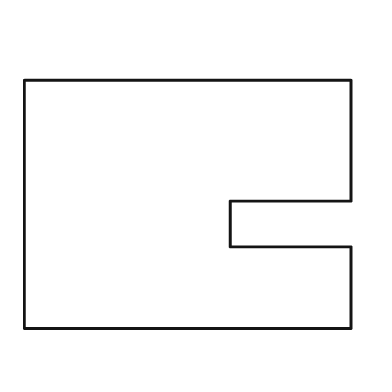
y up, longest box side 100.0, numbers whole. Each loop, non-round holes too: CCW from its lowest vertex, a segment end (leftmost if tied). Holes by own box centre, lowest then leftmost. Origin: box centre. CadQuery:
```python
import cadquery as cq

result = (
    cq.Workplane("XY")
    .moveTo(-50.0, -38.0)
    .lineTo(50.0, -38.0)
    .lineTo(50.0, -13.0)
    .lineTo(13.0, -13.0)
    .lineTo(13.0, 1.0)
    .lineTo(50.0, 1.0)
    .lineTo(50.0, 38.0)
    .lineTo(-50.0, 38.0)
    .close()
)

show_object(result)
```